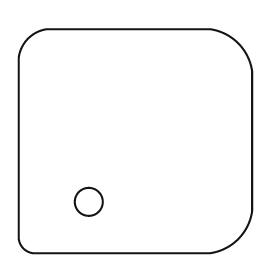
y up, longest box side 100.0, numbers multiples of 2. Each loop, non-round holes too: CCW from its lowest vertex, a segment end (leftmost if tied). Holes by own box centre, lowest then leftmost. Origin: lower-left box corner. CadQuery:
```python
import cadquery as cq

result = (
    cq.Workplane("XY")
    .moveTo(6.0, 0.0)
    .lineTo(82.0, 0.0)
    .threePointArc((94.0, 6.0), (100.0, 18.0))
    .lineTo(100.0, 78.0)
    .threePointArc((94.0, 90.0), (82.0, 96.0))
    .lineTo(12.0, 96.0)
    .threePointArc((4.0, 92.0), (0.0, 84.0))
    .lineTo(0.0, 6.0)
    .threePointArc((2.0, 2.0), (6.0, 0.0))
    .close()
    .moveTo(30.0, 22.0)
    .circle(6.0)
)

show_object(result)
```